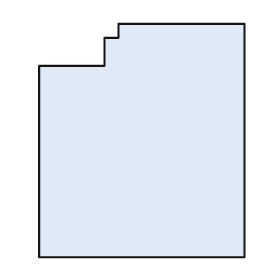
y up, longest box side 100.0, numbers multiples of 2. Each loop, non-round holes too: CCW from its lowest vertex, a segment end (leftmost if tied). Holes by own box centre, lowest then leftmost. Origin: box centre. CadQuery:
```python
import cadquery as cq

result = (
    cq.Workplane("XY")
    .moveTo(-44.0, -50.0)
    .lineTo(44.0, -50.0)
    .lineTo(44.0, 50.0)
    .lineTo(-10.0, 50.0)
    .lineTo(-10.0, 44.0)
    .lineTo(-16.0, 44.0)
    .lineTo(-16.0, 32.0)
    .lineTo(-44.0, 32.0)
    .close()
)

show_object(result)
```